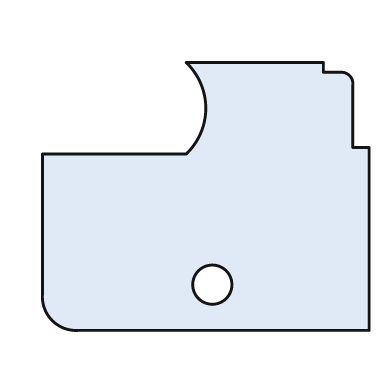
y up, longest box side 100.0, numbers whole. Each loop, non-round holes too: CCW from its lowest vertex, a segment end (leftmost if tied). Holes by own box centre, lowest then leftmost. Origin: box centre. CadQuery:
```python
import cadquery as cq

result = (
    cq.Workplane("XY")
    .moveTo(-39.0, -41.0)
    .lineTo(50.0, -41.0)
    .lineTo(50.0, 15.0)
    .lineTo(45.0, 15.0)
    .lineTo(45.0, 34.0)
    .threePointArc((44.0, 37.0), (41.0, 38.0))
    .lineTo(36.0, 38.0)
    .lineTo(36.0, 41.0)
    .lineTo(-6.0, 41.0)
    .threePointArc((0.0, 27.0), (-6.0, 13.0))
    .lineTo(-50.0, 13.0)
    .lineTo(-50.0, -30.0)
    .threePointArc((-47.0, -38.0), (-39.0, -41.0))
    .close()
    .moveTo(2.0, -27.0)
    .circle(6.0)
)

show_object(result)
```